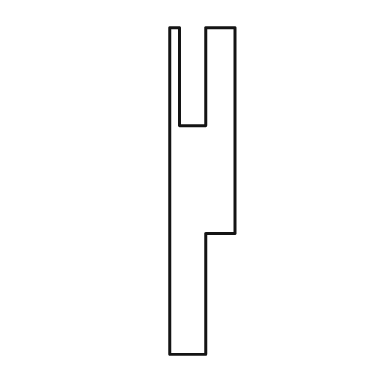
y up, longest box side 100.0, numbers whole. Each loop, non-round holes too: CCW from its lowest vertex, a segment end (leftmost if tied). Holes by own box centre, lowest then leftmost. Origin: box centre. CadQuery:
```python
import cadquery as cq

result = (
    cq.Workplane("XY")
    .moveTo(-10.0, -50.0)
    .lineTo(1.0, -50.0)
    .lineTo(1.0, -13.0)
    .lineTo(10.0, -13.0)
    .lineTo(10.0, 50.0)
    .lineTo(1.0, 50.0)
    .lineTo(1.0, 20.0)
    .lineTo(-7.0, 20.0)
    .lineTo(-7.0, 50.0)
    .lineTo(-10.0, 50.0)
    .close()
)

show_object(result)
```